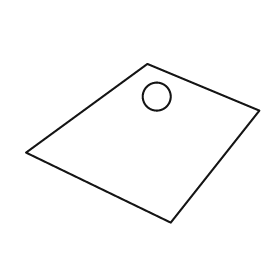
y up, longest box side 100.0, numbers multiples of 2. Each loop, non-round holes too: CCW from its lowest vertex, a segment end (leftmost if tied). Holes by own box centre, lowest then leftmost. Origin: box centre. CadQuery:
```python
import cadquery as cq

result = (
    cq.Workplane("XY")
    .moveTo(12.0, -34.0)
    .lineTo(50.0, 14.0)
    .lineTo(2.0, 34.0)
    .lineTo(-50.0, -4.0)
    .close()
    .moveTo(6.0, 20.0)
    .circle(6.0)
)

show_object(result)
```